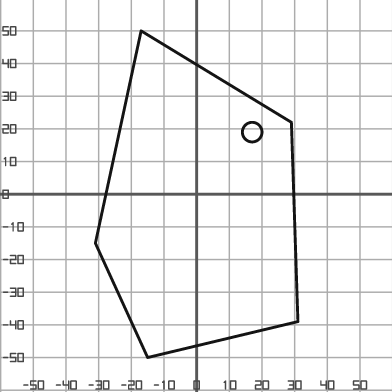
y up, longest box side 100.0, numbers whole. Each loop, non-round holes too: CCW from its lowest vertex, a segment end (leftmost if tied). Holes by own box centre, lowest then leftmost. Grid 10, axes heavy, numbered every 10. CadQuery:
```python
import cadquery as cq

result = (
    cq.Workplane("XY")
    .moveTo(-15.0, -50.0)
    .lineTo(31.0, -39.0)
    .lineTo(29.0, 22.0)
    .lineTo(-17.0, 50.0)
    .lineTo(-31.0, -15.0)
    .close()
    .moveTo(17.0, 19.0)
    .circle(3.0)
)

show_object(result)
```